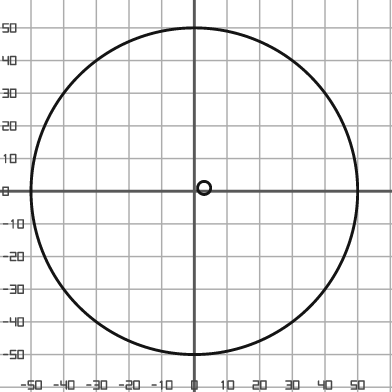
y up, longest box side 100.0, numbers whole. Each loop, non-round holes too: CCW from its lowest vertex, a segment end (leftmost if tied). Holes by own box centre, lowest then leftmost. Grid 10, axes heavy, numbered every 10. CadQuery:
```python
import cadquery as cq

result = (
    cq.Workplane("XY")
    .moveTo(0.0, 0.0)
    .circle(50.0)
    .moveTo(3.0, 1.0)
    .circle(2.0)
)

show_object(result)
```